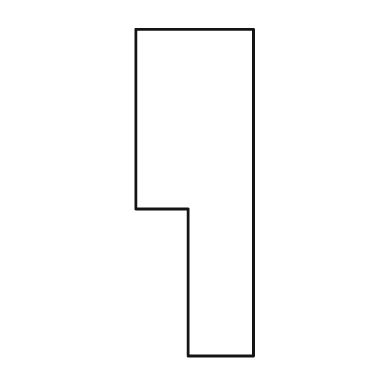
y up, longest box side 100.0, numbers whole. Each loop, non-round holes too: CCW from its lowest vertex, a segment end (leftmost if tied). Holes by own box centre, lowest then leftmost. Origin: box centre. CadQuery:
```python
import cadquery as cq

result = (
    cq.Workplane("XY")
    .moveTo(-2.0, -50.0)
    .lineTo(18.0, -50.0)
    .lineTo(18.0, 50.0)
    .lineTo(-18.0, 50.0)
    .lineTo(-18.0, -5.0)
    .lineTo(-2.0, -5.0)
    .close()
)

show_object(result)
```